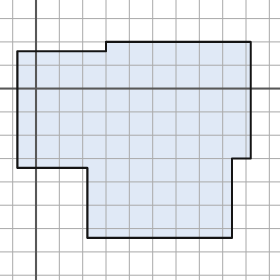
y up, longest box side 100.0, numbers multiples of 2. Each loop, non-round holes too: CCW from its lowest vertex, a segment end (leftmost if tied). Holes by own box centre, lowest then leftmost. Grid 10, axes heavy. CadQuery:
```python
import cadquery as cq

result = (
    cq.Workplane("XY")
    .moveTo(22.0, -64.0)
    .lineTo(84.0, -64.0)
    .lineTo(84.0, -30.0)
    .lineTo(92.0, -30.0)
    .lineTo(92.0, 20.0)
    .lineTo(30.0, 20.0)
    .lineTo(30.0, 16.0)
    .lineTo(-8.0, 16.0)
    .lineTo(-8.0, -34.0)
    .lineTo(22.0, -34.0)
    .close()
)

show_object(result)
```